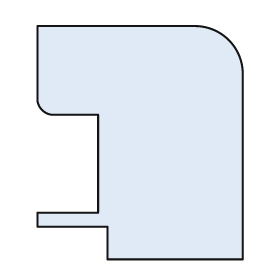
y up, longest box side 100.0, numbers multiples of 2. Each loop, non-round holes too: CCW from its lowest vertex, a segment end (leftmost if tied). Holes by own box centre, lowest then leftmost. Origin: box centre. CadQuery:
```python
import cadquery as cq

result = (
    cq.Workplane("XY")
    .moveTo(-14.0, -50.0)
    .lineTo(44.0, -50.0)
    .lineTo(44.0, 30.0)
    .threePointArc((38.0, 44.0), (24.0, 50.0))
    .lineTo(-44.0, 50.0)
    .lineTo(-44.0, 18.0)
    .threePointArc((-42.0, 14.0), (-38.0, 12.0))
    .lineTo(-18.0, 12.0)
    .lineTo(-18.0, -30.0)
    .lineTo(-44.0, -30.0)
    .lineTo(-44.0, -36.0)
    .lineTo(-14.0, -36.0)
    .close()
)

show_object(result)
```